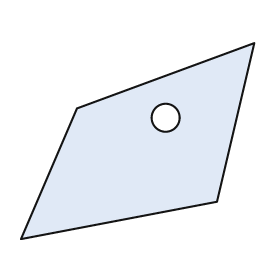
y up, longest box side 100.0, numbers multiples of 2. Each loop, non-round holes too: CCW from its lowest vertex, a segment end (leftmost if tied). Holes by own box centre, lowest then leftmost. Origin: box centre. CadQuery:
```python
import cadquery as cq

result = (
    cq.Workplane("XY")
    .moveTo(-50.0, -42.0)
    .lineTo(34.0, -26.0)
    .lineTo(50.0, 42.0)
    .lineTo(-26.0, 14.0)
    .close()
    .moveTo(12.0, 10.0)
    .circle(6.0)
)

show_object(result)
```